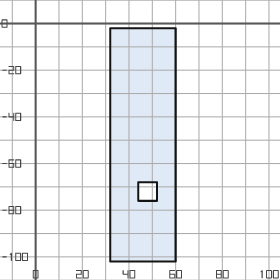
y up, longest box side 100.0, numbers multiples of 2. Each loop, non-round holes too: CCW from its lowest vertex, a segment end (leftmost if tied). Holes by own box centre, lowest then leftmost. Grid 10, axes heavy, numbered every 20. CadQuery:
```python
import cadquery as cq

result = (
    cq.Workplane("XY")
    .moveTo(32.0, -102.0)
    .lineTo(60.0, -102.0)
    .lineTo(60.0, -2.0)
    .lineTo(32.0, -2.0)
    .close()
    .moveTo(44.0, -76.0)
    .lineTo(52.0, -76.0)
    .lineTo(52.0, -68.0)
    .lineTo(44.0, -68.0)
    .close()
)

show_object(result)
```